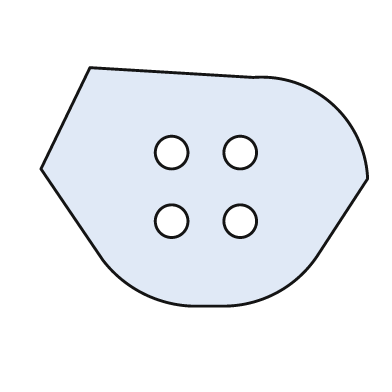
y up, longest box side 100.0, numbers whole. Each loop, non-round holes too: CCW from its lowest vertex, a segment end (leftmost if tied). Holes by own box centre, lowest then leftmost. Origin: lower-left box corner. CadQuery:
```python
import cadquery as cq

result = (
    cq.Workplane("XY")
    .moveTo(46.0, 0.0)
    .lineTo(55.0, 0.0)
    .threePointArc((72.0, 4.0), (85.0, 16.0))
    .lineTo(100.0, 39.0)
    .threePointArc((89.0, 62.0), (65.0, 70.0))
    .lineTo(15.0, 73.0)
    .lineTo(0.0, 42.0)
    .lineTo(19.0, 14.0)
    .threePointArc((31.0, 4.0), (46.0, 0.0))
    .close()
    .moveTo(40.0, 26.0)
    .circle(5.0)
    .moveTo(61.0, 26.0)
    .circle(5.0)
    .moveTo(40.0, 47.0)
    .circle(5.0)
    .moveTo(61.0, 47.0)
    .circle(5.0)
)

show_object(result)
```